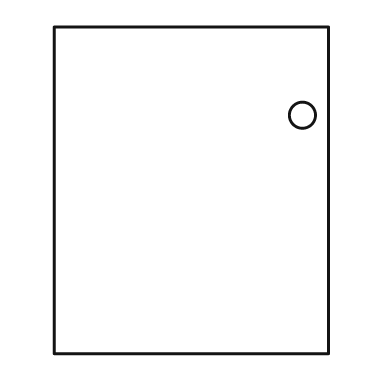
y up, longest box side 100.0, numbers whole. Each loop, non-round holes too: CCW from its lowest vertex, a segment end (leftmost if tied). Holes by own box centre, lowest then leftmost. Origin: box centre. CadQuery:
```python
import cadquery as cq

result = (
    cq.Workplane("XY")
    .moveTo(-42.0, -50.0)
    .lineTo(42.0, -50.0)
    .lineTo(42.0, 50.0)
    .lineTo(-42.0, 50.0)
    .close()
    .moveTo(34.0, 23.0)
    .circle(4.0)
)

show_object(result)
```